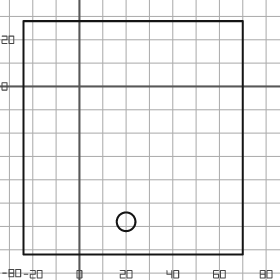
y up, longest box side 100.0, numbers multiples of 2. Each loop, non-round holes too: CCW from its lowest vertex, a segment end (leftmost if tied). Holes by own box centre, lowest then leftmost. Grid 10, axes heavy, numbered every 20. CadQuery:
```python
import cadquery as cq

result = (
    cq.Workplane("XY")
    .moveTo(-24.0, -72.0)
    .lineTo(70.0, -72.0)
    .lineTo(70.0, 28.0)
    .lineTo(-24.0, 28.0)
    .close()
    .moveTo(20.0, -58.0)
    .circle(4.0)
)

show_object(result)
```